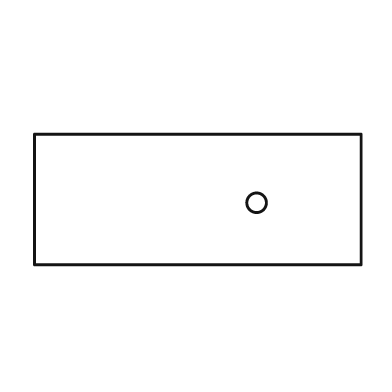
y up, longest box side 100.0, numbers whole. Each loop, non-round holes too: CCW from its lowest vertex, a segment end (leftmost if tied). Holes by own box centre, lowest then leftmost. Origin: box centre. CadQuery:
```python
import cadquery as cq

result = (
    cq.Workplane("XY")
    .moveTo(-50.0, -20.0)
    .lineTo(50.0, -20.0)
    .lineTo(50.0, 20.0)
    .lineTo(-50.0, 20.0)
    .close()
    .moveTo(18.0, -1.0)
    .circle(3.0)
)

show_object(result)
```